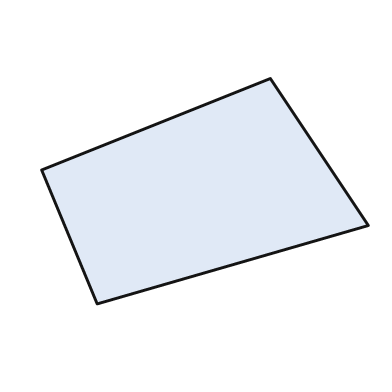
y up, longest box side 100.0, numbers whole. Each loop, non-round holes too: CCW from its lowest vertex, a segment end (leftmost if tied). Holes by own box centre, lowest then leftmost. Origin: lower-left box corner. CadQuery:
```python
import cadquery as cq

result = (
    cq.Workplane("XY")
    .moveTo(17.0, 0.0)
    .lineTo(100.0, 24.0)
    .lineTo(70.0, 69.0)
    .lineTo(0.0, 41.0)
    .close()
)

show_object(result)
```